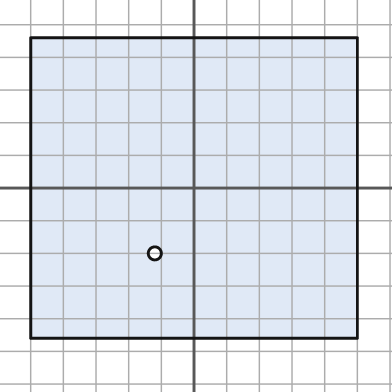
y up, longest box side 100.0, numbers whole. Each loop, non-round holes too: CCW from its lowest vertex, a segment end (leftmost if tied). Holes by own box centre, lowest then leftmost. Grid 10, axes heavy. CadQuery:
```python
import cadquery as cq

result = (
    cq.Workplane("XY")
    .moveTo(-50.0, -46.0)
    .lineTo(50.0, -46.0)
    .lineTo(50.0, 46.0)
    .lineTo(-50.0, 46.0)
    .close()
    .moveTo(-12.0, -20.0)
    .circle(2.0)
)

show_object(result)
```